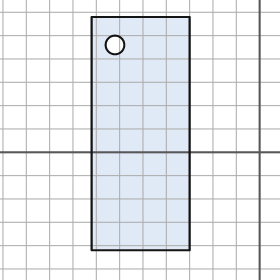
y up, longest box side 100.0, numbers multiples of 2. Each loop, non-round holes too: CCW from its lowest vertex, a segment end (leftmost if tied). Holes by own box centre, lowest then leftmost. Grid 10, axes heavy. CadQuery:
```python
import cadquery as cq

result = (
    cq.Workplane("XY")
    .moveTo(-72.0, -42.0)
    .lineTo(-30.0, -42.0)
    .lineTo(-30.0, 58.0)
    .lineTo(-72.0, 58.0)
    .close()
    .moveTo(-62.0, 46.0)
    .circle(4.0)
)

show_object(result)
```